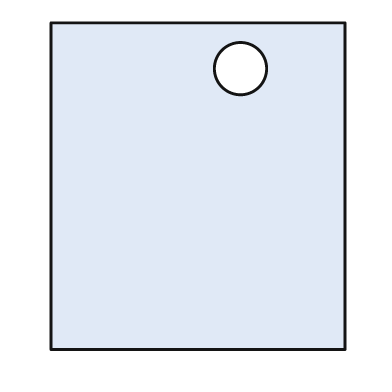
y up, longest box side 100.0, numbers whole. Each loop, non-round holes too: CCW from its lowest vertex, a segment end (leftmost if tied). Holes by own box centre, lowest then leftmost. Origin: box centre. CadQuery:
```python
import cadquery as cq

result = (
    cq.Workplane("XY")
    .moveTo(-45.0, -50.0)
    .lineTo(45.0, -50.0)
    .lineTo(45.0, 50.0)
    .lineTo(-45.0, 50.0)
    .close()
    .moveTo(13.0, 36.0)
    .circle(8.0)
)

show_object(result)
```